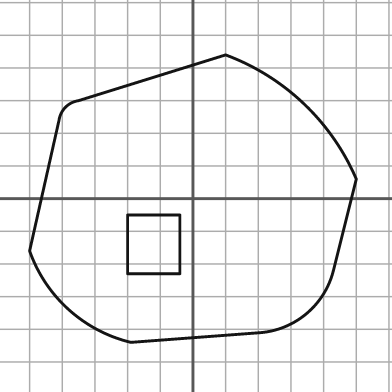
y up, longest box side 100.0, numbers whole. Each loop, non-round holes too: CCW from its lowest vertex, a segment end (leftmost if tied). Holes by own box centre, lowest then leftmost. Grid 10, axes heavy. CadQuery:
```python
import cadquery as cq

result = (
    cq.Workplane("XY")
    .moveTo(-19.0, -44.0)
    .lineTo(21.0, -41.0)
    .threePointArc((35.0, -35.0), (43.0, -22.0))
    .lineTo(50.0, 6.0)
    .threePointArc((34.0, 29.0), (10.0, 44.0))
    .lineTo(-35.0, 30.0)
    .threePointArc((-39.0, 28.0), (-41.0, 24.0))
    .lineTo(-50.0, -16.0)
    .threePointArc((-38.0, -34.0), (-19.0, -44.0))
    .close()
    .moveTo(-20.0, -23.0)
    .lineTo(-4.0, -23.0)
    .lineTo(-4.0, -5.0)
    .lineTo(-20.0, -5.0)
    .close()
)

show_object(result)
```